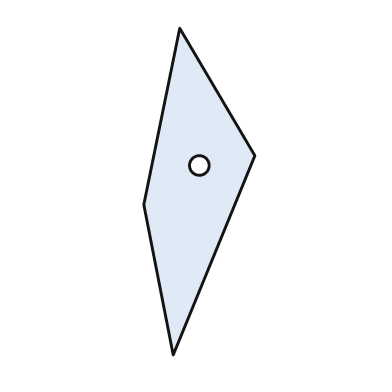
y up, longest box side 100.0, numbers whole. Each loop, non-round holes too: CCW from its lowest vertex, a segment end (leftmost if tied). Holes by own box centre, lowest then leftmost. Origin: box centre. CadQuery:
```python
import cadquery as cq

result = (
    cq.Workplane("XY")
    .moveTo(-8.0, -50.0)
    .lineTo(17.0, 11.0)
    .lineTo(-6.0, 50.0)
    .lineTo(-17.0, -4.0)
    .close()
    .moveTo(0.0, 8.0)
    .circle(3.0)
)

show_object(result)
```